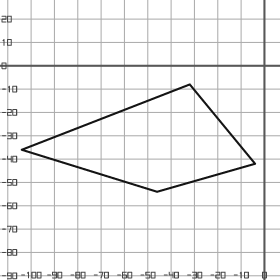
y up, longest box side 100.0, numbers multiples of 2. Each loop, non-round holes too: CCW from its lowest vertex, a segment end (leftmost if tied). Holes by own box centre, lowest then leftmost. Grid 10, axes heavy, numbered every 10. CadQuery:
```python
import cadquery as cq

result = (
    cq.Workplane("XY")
    .moveTo(-46.0, -54.0)
    .lineTo(-4.0, -42.0)
    .lineTo(-32.0, -8.0)
    .lineTo(-104.0, -36.0)
    .close()
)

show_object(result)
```